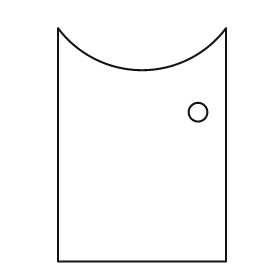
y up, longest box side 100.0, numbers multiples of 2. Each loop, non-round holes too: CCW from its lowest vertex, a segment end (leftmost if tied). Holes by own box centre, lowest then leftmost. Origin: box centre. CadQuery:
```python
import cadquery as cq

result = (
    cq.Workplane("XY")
    .moveTo(-36.0, -50.0)
    .lineTo(36.0, -50.0)
    .lineTo(36.0, 50.0)
    .threePointArc((0.0, 32.0), (-36.0, 50.0))
    .close()
    .moveTo(24.0, 14.0)
    .circle(4.0)
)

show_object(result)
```